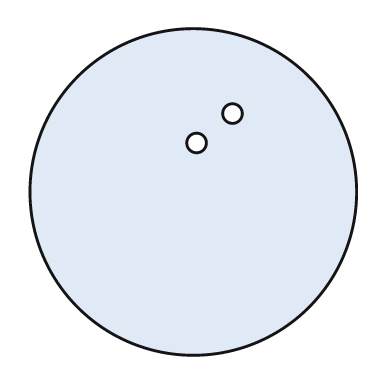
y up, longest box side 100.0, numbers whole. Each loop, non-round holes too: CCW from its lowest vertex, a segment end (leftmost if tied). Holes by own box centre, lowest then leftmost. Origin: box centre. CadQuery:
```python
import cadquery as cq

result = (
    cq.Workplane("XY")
    .moveTo(0.0, 0.0)
    .circle(50.0)
    .moveTo(1.0, 15.0)
    .circle(3.0)
    .moveTo(12.0, 24.0)
    .circle(3.0)
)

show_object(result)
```